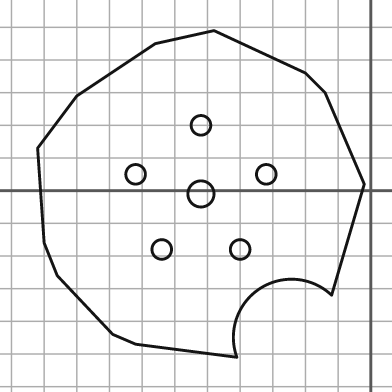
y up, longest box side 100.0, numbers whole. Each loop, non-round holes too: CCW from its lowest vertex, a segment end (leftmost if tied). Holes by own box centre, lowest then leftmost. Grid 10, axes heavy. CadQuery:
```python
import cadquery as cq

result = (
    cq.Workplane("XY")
    .moveTo(-41.0, -51.0)
    .threePointArc((-34.0, -30.0), (-12.0, -32.0))
    .lineTo(-2.0, 2.0)
    .lineTo(-14.0, 30.0)
    .lineTo(-20.0, 36.0)
    .lineTo(-48.0, 49.0)
    .lineTo(-66.0, 45.0)
    .lineTo(-90.0, 29.0)
    .lineTo(-102.0, 13.0)
    .lineTo(-100.0, -16.0)
    .lineTo(-96.0, -26.0)
    .lineTo(-79.0, -44.0)
    .lineTo(-72.0, -47.0)
    .close()
    .moveTo(-64.0, -18.0)
    .circle(3.0)
    .moveTo(-40.0, -18.0)
    .circle(3.0)
    .moveTo(-52.0, -1.0)
    .circle(4.0)
    .moveTo(-72.0, 5.0)
    .circle(3.0)
    .moveTo(-32.0, 5.0)
    .circle(3.0)
    .moveTo(-52.0, 20.0)
    .circle(3.0)
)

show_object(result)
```